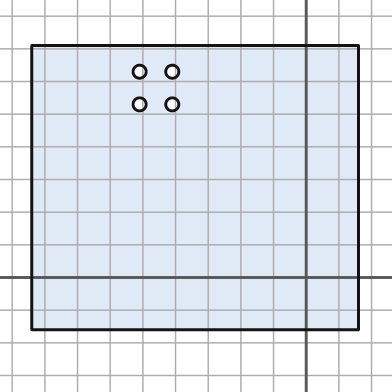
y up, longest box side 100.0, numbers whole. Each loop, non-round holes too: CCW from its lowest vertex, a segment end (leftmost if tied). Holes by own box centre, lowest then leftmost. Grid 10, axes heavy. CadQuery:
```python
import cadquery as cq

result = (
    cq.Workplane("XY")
    .moveTo(-84.0, -16.0)
    .lineTo(16.0, -16.0)
    .lineTo(16.0, 71.0)
    .lineTo(-84.0, 71.0)
    .close()
    .moveTo(-51.0, 53.0)
    .circle(2.0)
    .moveTo(-41.0, 53.0)
    .circle(2.0)
    .moveTo(-51.0, 63.0)
    .circle(2.0)
    .moveTo(-41.0, 63.0)
    .circle(2.0)
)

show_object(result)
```